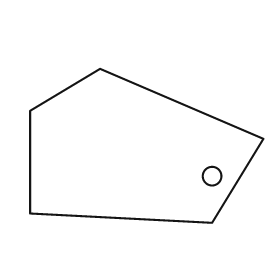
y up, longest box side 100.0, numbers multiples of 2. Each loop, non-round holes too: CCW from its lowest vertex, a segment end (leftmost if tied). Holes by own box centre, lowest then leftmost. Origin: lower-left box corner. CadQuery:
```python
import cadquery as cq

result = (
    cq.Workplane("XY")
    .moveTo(78.0, 0.0)
    .lineTo(100.0, 36.0)
    .lineTo(30.0, 66.0)
    .lineTo(0.0, 48.0)
    .lineTo(0.0, 4.0)
    .close()
    .moveTo(78.0, 20.0)
    .circle(4.0)
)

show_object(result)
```